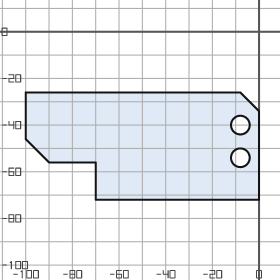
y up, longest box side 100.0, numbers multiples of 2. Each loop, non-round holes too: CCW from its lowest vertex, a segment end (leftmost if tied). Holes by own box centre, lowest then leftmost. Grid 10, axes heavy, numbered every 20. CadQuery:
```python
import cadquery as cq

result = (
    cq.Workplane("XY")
    .moveTo(-70.0, -72.0)
    .lineTo(0.0, -72.0)
    .lineTo(0.0, -34.0)
    .lineTo(-8.0, -26.0)
    .lineTo(-100.0, -26.0)
    .lineTo(-100.0, -46.0)
    .lineTo(-90.0, -56.0)
    .lineTo(-70.0, -56.0)
    .close()
    .moveTo(-8.0, -54.0)
    .circle(4.0)
    .moveTo(-8.0, -40.0)
    .circle(4.0)
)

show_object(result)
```